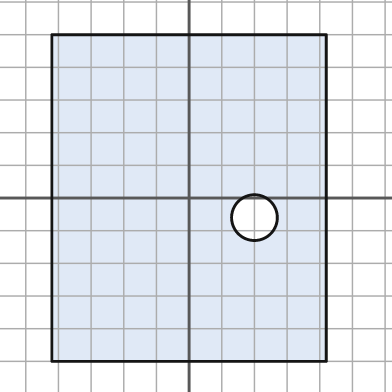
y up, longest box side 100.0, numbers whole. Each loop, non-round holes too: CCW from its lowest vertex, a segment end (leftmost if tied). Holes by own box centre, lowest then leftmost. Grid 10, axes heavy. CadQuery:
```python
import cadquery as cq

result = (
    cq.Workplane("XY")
    .moveTo(-42.0, -50.0)
    .lineTo(42.0, -50.0)
    .lineTo(42.0, 50.0)
    .lineTo(-42.0, 50.0)
    .close()
    .moveTo(20.0, -6.0)
    .circle(7.0)
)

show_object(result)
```